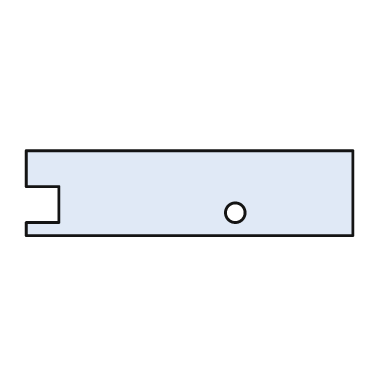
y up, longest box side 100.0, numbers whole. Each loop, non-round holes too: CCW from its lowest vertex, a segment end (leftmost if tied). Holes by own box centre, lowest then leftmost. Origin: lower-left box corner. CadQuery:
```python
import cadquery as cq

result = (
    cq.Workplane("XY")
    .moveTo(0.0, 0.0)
    .lineTo(100.0, 0.0)
    .lineTo(100.0, 26.0)
    .lineTo(0.0, 26.0)
    .lineTo(0.0, 15.0)
    .lineTo(10.0, 15.0)
    .lineTo(10.0, 4.0)
    .lineTo(0.0, 4.0)
    .close()
    .moveTo(64.0, 7.0)
    .circle(3.0)
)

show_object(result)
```